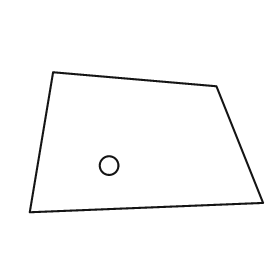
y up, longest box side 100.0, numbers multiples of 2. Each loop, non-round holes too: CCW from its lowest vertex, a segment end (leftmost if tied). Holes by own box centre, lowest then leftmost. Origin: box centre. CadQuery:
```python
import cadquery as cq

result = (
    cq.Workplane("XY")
    .moveTo(-50.0, -30.0)
    .lineTo(50.0, -26.0)
    .lineTo(30.0, 24.0)
    .lineTo(-40.0, 30.0)
    .close()
    .moveTo(-16.0, -10.0)
    .circle(4.0)
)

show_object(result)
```